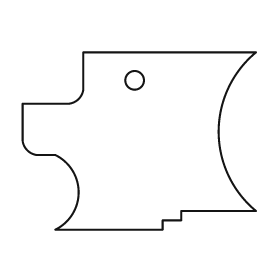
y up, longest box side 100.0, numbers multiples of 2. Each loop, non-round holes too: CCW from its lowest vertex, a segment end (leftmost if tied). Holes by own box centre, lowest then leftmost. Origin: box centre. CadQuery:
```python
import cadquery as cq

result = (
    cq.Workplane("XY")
    .moveTo(-36.0, -38.0)
    .lineTo(10.0, -38.0)
    .lineTo(10.0, -34.0)
    .lineTo(18.0, -34.0)
    .lineTo(18.0, -30.0)
    .lineTo(50.0, -30.0)
    .threePointArc((34.0, 4.0), (50.0, 38.0))
    .lineTo(-24.0, 38.0)
    .lineTo(-24.0, 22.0)
    .threePointArc((-26.0, 18.0), (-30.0, 16.0))
    .lineTo(-50.0, 16.0)
    .lineTo(-50.0, 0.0)
    .threePointArc((-48.0, -4.0), (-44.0, -6.0))
    .lineTo(-36.0, -6.0)
    .threePointArc((-26.0, -22.0), (-36.0, -38.0))
    .close()
    .moveTo(-2.0, 26.0)
    .circle(4.0)
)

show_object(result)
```